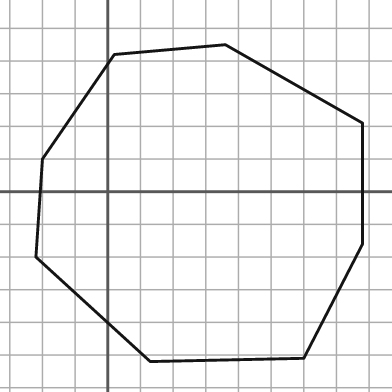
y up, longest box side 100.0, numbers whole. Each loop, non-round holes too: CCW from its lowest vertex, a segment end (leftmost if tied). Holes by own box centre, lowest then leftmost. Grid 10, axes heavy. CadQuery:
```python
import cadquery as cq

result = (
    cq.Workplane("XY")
    .moveTo(13.0, -52.0)
    .lineTo(60.0, -51.0)
    .lineTo(78.0, -16.0)
    .lineTo(78.0, 21.0)
    .lineTo(36.0, 45.0)
    .lineTo(2.0, 42.0)
    .lineTo(-20.0, 10.0)
    .lineTo(-22.0, -20.0)
    .close()
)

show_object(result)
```